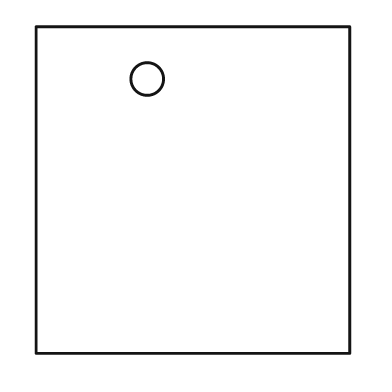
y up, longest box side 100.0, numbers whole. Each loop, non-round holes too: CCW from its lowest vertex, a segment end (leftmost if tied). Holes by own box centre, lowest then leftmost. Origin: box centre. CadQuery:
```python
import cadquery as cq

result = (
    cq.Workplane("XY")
    .moveTo(-48.0, -50.0)
    .lineTo(48.0, -50.0)
    .lineTo(48.0, 50.0)
    .lineTo(-48.0, 50.0)
    .close()
    .moveTo(-14.0, 34.0)
    .circle(5.0)
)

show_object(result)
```